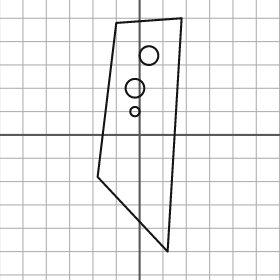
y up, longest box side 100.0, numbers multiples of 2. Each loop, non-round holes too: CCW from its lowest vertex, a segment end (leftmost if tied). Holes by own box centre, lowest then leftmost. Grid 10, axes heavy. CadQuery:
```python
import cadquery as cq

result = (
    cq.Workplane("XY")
    .moveTo(12.0, -50.0)
    .lineTo(18.0, 50.0)
    .lineTo(-10.0, 48.0)
    .lineTo(-18.0, -18.0)
    .close()
    .moveTo(-2.0, 10.0)
    .circle(2.0)
    .moveTo(-2.0, 20.0)
    .circle(4.0)
    .moveTo(4.0, 34.0)
    .circle(4.0)
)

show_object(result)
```